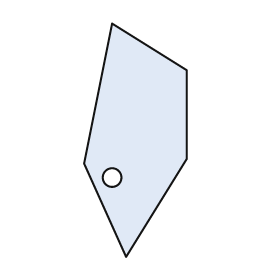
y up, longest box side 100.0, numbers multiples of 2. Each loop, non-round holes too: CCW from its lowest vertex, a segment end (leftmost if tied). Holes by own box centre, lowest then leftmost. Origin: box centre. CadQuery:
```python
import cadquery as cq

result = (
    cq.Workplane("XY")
    .moveTo(-4.0, -50.0)
    .lineTo(22.0, -8.0)
    .lineTo(22.0, 30.0)
    .lineTo(-10.0, 50.0)
    .lineTo(-22.0, -10.0)
    .close()
    .moveTo(-10.0, -16.0)
    .circle(4.0)
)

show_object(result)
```